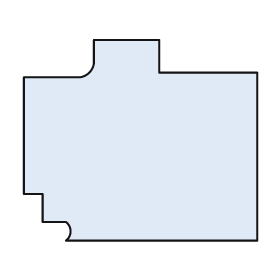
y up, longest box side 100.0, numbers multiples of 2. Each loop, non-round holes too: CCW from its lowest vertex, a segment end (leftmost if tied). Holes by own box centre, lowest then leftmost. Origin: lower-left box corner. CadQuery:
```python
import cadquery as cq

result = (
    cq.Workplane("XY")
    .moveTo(18.0, 0.0)
    .lineTo(100.0, 0.0)
    .lineTo(100.0, 72.0)
    .lineTo(58.0, 72.0)
    .lineTo(58.0, 86.0)
    .lineTo(30.0, 86.0)
    .lineTo(30.0, 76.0)
    .threePointArc((28.0, 72.0), (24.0, 70.0))
    .lineTo(0.0, 70.0)
    .lineTo(0.0, 20.0)
    .lineTo(8.0, 20.0)
    .lineTo(8.0, 8.0)
    .lineTo(18.0, 8.0)
    .threePointArc((20.0, 4.0), (18.0, 0.0))
    .close()
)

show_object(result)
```